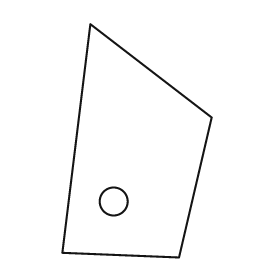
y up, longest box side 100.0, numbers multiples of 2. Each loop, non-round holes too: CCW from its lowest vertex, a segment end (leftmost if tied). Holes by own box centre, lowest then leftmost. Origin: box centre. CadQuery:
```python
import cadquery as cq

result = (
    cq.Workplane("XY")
    .moveTo(18.0, -50.0)
    .lineTo(32.0, 10.0)
    .lineTo(-20.0, 50.0)
    .lineTo(-32.0, -48.0)
    .close()
    .moveTo(-10.0, -26.0)
    .circle(6.0)
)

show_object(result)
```